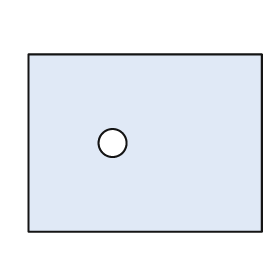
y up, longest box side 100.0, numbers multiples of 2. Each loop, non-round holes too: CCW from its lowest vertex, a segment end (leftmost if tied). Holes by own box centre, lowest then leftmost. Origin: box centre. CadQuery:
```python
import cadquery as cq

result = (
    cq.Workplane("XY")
    .moveTo(-50.0, -38.0)
    .lineTo(50.0, -38.0)
    .lineTo(50.0, 38.0)
    .lineTo(-50.0, 38.0)
    .close()
    .moveTo(-14.0, 0.0)
    .circle(6.0)
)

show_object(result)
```